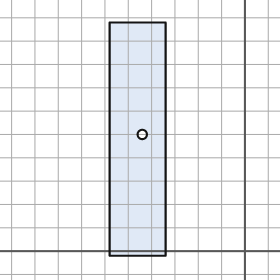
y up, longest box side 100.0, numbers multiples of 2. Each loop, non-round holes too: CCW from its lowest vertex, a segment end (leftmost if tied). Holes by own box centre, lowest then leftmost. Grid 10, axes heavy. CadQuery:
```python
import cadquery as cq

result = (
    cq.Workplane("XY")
    .moveTo(-58.0, -2.0)
    .lineTo(-34.0, -2.0)
    .lineTo(-34.0, 98.0)
    .lineTo(-58.0, 98.0)
    .close()
    .moveTo(-44.0, 50.0)
    .circle(2.0)
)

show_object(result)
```